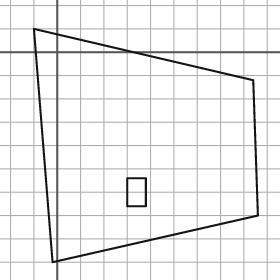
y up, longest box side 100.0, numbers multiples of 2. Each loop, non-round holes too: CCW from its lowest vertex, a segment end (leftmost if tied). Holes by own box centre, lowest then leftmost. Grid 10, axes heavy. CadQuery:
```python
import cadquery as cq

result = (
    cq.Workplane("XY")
    .moveTo(-2.0, -90.0)
    .lineTo(86.0, -70.0)
    .lineTo(84.0, -12.0)
    .lineTo(-10.0, 10.0)
    .close()
    .moveTo(30.0, -66.0)
    .lineTo(38.0, -66.0)
    .lineTo(38.0, -54.0)
    .lineTo(30.0, -54.0)
    .close()
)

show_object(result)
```